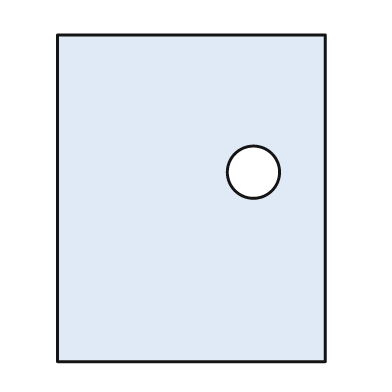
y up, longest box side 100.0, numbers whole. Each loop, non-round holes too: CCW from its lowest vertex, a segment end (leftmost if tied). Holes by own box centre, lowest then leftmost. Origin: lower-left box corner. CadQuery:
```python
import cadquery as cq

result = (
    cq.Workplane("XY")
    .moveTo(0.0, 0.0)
    .lineTo(82.0, 0.0)
    .lineTo(82.0, 100.0)
    .lineTo(0.0, 100.0)
    .close()
    .moveTo(60.0, 58.0)
    .circle(8.0)
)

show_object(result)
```